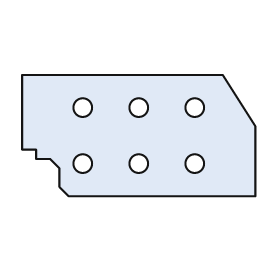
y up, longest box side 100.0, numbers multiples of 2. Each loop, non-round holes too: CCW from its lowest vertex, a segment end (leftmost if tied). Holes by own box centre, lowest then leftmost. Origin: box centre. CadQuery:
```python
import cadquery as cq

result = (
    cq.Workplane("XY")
    .moveTo(-30.0, -26.0)
    .lineTo(50.0, -26.0)
    .lineTo(50.0, 4.0)
    .lineTo(36.0, 26.0)
    .lineTo(-50.0, 26.0)
    .lineTo(-50.0, -6.0)
    .lineTo(-44.0, -6.0)
    .lineTo(-44.0, -10.0)
    .lineTo(-38.0, -10.0)
    .lineTo(-34.0, -14.0)
    .lineTo(-34.0, -22.0)
    .close()
    .moveTo(-24.0, -12.0)
    .circle(4.0)
    .moveTo(0.0, -12.0)
    .circle(4.0)
    .moveTo(24.0, -12.0)
    .circle(4.0)
    .moveTo(-24.0, 12.0)
    .circle(4.0)
    .moveTo(0.0, 12.0)
    .circle(4.0)
    .moveTo(24.0, 12.0)
    .circle(4.0)
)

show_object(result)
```